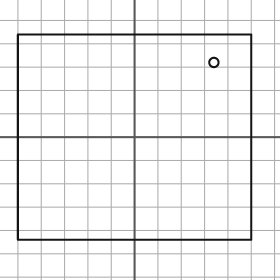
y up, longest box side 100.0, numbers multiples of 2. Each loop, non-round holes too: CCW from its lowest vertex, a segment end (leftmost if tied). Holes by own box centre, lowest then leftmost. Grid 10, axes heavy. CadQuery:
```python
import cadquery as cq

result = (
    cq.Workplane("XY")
    .moveTo(-50.0, -44.0)
    .lineTo(50.0, -44.0)
    .lineTo(50.0, 44.0)
    .lineTo(-50.0, 44.0)
    .close()
    .moveTo(34.0, 32.0)
    .circle(2.0)
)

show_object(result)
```